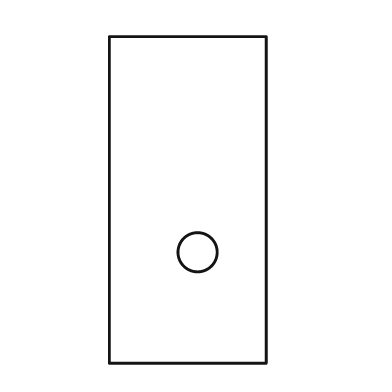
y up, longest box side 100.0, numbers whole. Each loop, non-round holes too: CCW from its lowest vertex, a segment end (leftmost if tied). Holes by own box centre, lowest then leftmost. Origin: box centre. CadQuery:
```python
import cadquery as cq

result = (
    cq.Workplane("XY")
    .moveTo(-24.0, -50.0)
    .lineTo(24.0, -50.0)
    .lineTo(24.0, 50.0)
    .lineTo(-24.0, 50.0)
    .close()
    .moveTo(3.0, -16.0)
    .circle(6.0)
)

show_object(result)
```